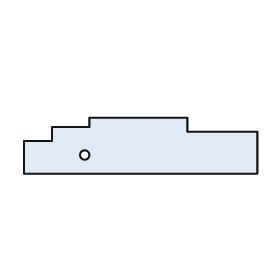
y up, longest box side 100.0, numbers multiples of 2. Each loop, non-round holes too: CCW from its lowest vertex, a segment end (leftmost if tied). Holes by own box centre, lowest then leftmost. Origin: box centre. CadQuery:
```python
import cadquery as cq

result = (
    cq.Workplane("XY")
    .moveTo(-50.0, -12.0)
    .lineTo(50.0, -12.0)
    .lineTo(50.0, 6.0)
    .lineTo(20.0, 6.0)
    .lineTo(20.0, 12.0)
    .lineTo(-22.0, 12.0)
    .lineTo(-22.0, 8.0)
    .lineTo(-38.0, 8.0)
    .lineTo(-38.0, 2.0)
    .lineTo(-50.0, 2.0)
    .close()
    .moveTo(-24.0, -4.0)
    .circle(2.0)
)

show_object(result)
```